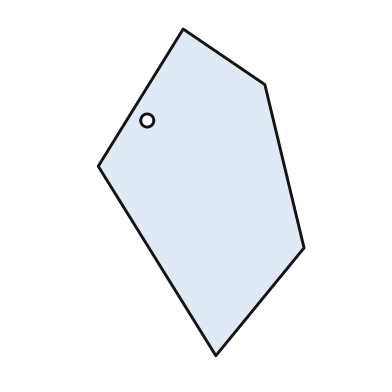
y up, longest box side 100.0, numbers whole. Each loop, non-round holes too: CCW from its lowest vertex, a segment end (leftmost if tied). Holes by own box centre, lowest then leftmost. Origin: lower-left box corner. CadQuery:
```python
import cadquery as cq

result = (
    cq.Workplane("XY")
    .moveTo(36.0, 0.0)
    .lineTo(63.0, 33.0)
    .lineTo(51.0, 83.0)
    .lineTo(26.0, 100.0)
    .lineTo(0.0, 58.0)
    .close()
    .moveTo(15.0, 72.0)
    .circle(2.0)
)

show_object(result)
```